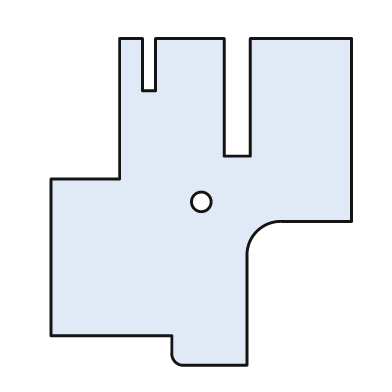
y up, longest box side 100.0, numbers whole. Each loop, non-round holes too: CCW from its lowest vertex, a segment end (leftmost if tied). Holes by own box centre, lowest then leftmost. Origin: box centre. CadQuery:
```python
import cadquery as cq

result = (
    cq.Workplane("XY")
    .moveTo(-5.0, -50.0)
    .lineTo(14.0, -50.0)
    .lineTo(14.0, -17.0)
    .threePointArc((17.0, -9.0), (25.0, -6.0))
    .lineTo(46.0, -6.0)
    .lineTo(46.0, 50.0)
    .lineTo(15.0, 50.0)
    .lineTo(15.0, 14.0)
    .lineTo(7.0, 14.0)
    .lineTo(7.0, 50.0)
    .lineTo(-14.0, 50.0)
    .lineTo(-14.0, 34.0)
    .lineTo(-18.0, 34.0)
    .lineTo(-18.0, 50.0)
    .lineTo(-25.0, 50.0)
    .lineTo(-25.0, 7.0)
    .lineTo(-46.0, 7.0)
    .lineTo(-46.0, -41.0)
    .lineTo(-9.0, -41.0)
    .lineTo(-9.0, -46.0)
    .threePointArc((-8.0, -49.0), (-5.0, -50.0))
    .close()
    .moveTo(0.0, 0.0)
    .circle(3.0)
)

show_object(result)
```